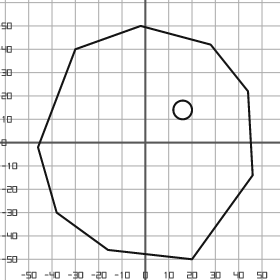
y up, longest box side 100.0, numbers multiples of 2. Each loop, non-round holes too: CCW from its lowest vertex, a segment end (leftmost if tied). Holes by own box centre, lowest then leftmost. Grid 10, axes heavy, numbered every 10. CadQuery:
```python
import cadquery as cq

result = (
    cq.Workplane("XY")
    .moveTo(20.0, -50.0)
    .lineTo(46.0, -14.0)
    .lineTo(44.0, 22.0)
    .lineTo(28.0, 42.0)
    .lineTo(-2.0, 50.0)
    .lineTo(-30.0, 40.0)
    .lineTo(-46.0, -2.0)
    .lineTo(-38.0, -30.0)
    .lineTo(-16.0, -46.0)
    .close()
    .moveTo(16.0, 14.0)
    .circle(4.0)
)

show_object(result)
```